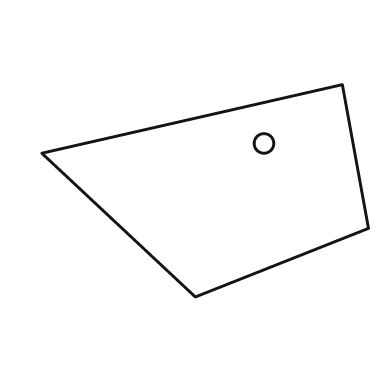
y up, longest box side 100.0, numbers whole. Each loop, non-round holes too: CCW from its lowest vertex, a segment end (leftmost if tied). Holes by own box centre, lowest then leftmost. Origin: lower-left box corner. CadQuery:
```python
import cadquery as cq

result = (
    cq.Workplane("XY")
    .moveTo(47.0, 0.0)
    .lineTo(100.0, 21.0)
    .lineTo(92.0, 65.0)
    .lineTo(0.0, 44.0)
    .close()
    .moveTo(68.0, 47.0)
    .circle(3.0)
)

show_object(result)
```